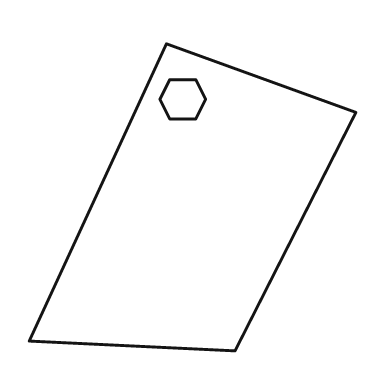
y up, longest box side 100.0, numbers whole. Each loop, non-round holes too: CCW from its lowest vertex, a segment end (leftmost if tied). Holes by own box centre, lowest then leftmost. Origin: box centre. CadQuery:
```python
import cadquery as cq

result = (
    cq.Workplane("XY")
    .moveTo(13.0, -47.0)
    .lineTo(50.0, 26.0)
    .lineTo(-8.0, 47.0)
    .lineTo(-50.0, -44.0)
    .close()
    .moveTo(-7.0, 24.0)
    .lineTo(1.0, 24.0)
    .lineTo(4.0, 30.0)
    .lineTo(1.0, 36.0)
    .lineTo(-7.0, 36.0)
    .lineTo(-10.0, 30.0)
    .close()
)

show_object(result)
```